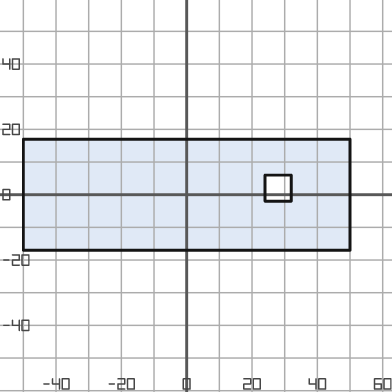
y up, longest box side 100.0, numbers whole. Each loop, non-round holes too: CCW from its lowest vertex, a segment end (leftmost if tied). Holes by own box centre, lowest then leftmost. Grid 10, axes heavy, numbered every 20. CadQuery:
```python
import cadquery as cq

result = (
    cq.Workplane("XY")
    .moveTo(-50.0, -17.0)
    .lineTo(50.0, -17.0)
    .lineTo(50.0, 17.0)
    .lineTo(-50.0, 17.0)
    .close()
    .moveTo(24.0, -2.0)
    .lineTo(32.0, -2.0)
    .lineTo(32.0, 6.0)
    .lineTo(24.0, 6.0)
    .close()
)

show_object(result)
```